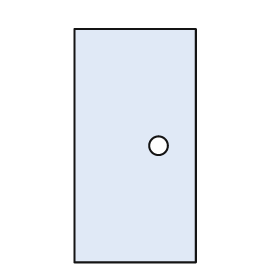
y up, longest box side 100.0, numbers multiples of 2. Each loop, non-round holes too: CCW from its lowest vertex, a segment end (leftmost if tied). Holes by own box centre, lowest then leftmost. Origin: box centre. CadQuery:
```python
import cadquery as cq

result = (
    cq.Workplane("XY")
    .moveTo(-26.0, -50.0)
    .lineTo(26.0, -50.0)
    .lineTo(26.0, 50.0)
    .lineTo(-26.0, 50.0)
    .close()
    .moveTo(10.0, 0.0)
    .circle(4.0)
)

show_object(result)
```